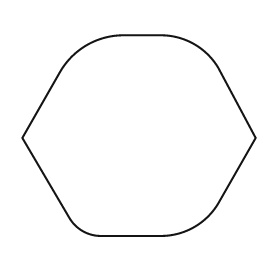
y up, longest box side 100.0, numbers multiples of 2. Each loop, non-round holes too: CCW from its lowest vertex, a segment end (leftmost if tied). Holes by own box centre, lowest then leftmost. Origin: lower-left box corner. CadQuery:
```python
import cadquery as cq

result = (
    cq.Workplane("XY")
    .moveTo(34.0, 0.0)
    .lineTo(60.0, 0.0)
    .threePointArc((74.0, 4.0), (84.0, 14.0))
    .lineTo(100.0, 42.0)
    .lineTo(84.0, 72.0)
    .threePointArc((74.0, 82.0), (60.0, 86.0))
    .lineTo(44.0, 86.0)
    .threePointArc((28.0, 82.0), (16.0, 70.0))
    .lineTo(0.0, 42.0)
    .lineTo(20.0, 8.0)
    .threePointArc((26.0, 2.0), (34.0, 0.0))
    .close()
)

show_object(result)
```